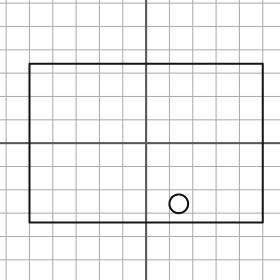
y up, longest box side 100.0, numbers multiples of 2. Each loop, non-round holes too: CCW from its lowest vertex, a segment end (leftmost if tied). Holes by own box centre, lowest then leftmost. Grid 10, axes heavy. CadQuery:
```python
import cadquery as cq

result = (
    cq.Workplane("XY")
    .moveTo(-50.0, -34.0)
    .lineTo(50.0, -34.0)
    .lineTo(50.0, 34.0)
    .lineTo(-50.0, 34.0)
    .close()
    .moveTo(14.0, -26.0)
    .circle(4.0)
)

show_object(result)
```